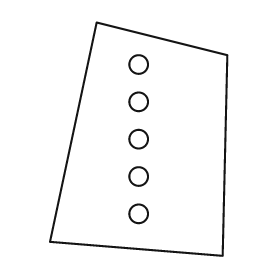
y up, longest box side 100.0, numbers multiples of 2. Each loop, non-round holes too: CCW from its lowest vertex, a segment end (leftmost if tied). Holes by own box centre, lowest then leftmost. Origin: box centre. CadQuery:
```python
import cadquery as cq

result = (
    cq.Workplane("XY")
    .moveTo(36.0, -50.0)
    .lineTo(38.0, 36.0)
    .lineTo(-18.0, 50.0)
    .lineTo(-38.0, -44.0)
    .close()
    .moveTo(0.0, -32.0)
    .circle(4.0)
    .moveTo(0.0, -16.0)
    .circle(4.0)
    .moveTo(0.0, 0.0)
    .circle(4.0)
    .moveTo(0.0, 16.0)
    .circle(4.0)
    .moveTo(0.0, 32.0)
    .circle(4.0)
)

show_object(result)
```